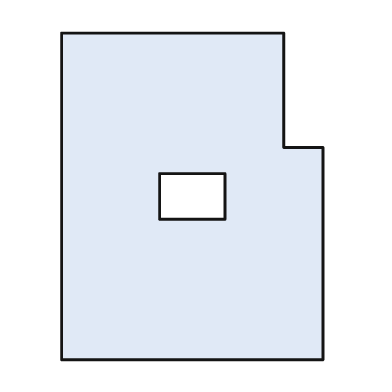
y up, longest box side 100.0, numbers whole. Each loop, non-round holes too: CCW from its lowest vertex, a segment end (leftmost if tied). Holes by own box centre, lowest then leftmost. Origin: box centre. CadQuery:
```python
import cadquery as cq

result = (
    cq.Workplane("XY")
    .moveTo(-40.0, -50.0)
    .lineTo(40.0, -50.0)
    .lineTo(40.0, 15.0)
    .lineTo(28.0, 15.0)
    .lineTo(28.0, 50.0)
    .lineTo(-40.0, 50.0)
    .close()
    .moveTo(-10.0, -7.0)
    .lineTo(10.0, -7.0)
    .lineTo(10.0, 7.0)
    .lineTo(-10.0, 7.0)
    .close()
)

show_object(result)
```